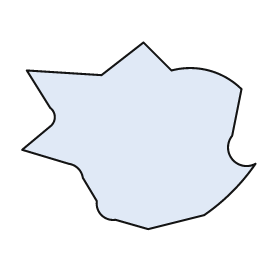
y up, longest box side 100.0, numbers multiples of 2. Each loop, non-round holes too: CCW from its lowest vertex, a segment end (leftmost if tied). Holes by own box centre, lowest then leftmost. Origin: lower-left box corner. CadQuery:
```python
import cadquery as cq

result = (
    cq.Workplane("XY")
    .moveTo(54.0, 0.0)
    .lineTo(78.0, 6.0)
    .threePointArc((90.0, 16.0), (100.0, 28.0))
    .threePointArc((90.0, 30.0), (90.0, 40.0))
    .lineTo(94.0, 60.0)
    .threePointArc((80.0, 68.0), (64.0, 68.0))
    .lineTo(52.0, 80.0)
    .lineTo(34.0, 66.0)
    .lineTo(2.0, 68.0)
    .lineTo(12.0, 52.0)
    .threePointArc((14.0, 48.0), (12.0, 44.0))
    .lineTo(0.0, 34.0)
    .lineTo(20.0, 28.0)
    .threePointArc((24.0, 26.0), (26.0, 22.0))
    .lineTo(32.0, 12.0)
    .threePointArc((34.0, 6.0), (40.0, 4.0))
    .close()
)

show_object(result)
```